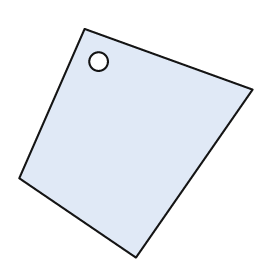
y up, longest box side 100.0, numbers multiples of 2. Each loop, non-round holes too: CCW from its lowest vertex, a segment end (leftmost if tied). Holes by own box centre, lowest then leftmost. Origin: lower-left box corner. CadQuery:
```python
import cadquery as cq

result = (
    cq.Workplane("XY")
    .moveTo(50.0, 0.0)
    .lineTo(100.0, 72.0)
    .lineTo(28.0, 98.0)
    .lineTo(0.0, 34.0)
    .close()
    .moveTo(34.0, 84.0)
    .circle(4.0)
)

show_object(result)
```